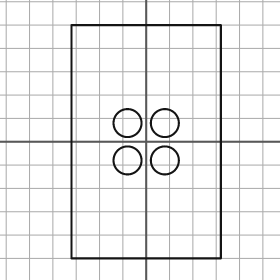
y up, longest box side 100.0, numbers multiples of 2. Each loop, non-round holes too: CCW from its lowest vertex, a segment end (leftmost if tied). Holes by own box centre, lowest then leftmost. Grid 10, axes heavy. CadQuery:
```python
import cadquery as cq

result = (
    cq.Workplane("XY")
    .moveTo(-32.0, -50.0)
    .lineTo(32.0, -50.0)
    .lineTo(32.0, 50.0)
    .lineTo(-32.0, 50.0)
    .close()
    .moveTo(-8.0, -8.0)
    .circle(6.0)
    .moveTo(8.0, -8.0)
    .circle(6.0)
    .moveTo(-8.0, 8.0)
    .circle(6.0)
    .moveTo(8.0, 8.0)
    .circle(6.0)
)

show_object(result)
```